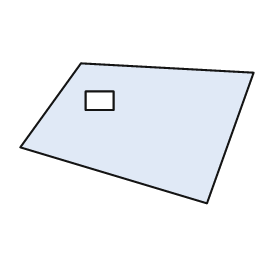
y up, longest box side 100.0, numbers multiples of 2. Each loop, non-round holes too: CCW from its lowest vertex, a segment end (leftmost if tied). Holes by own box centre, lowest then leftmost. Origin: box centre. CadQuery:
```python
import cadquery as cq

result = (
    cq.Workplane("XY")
    .moveTo(30.0, -30.0)
    .lineTo(50.0, 26.0)
    .lineTo(-24.0, 30.0)
    .lineTo(-50.0, -6.0)
    .close()
    .moveTo(-22.0, 10.0)
    .lineTo(-10.0, 10.0)
    .lineTo(-10.0, 18.0)
    .lineTo(-22.0, 18.0)
    .close()
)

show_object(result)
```